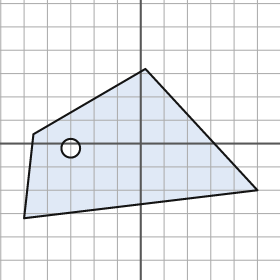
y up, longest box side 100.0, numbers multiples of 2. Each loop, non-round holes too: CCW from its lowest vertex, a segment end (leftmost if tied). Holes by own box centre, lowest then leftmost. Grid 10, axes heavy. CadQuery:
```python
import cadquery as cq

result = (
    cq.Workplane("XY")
    .moveTo(-50.0, -32.0)
    .lineTo(50.0, -20.0)
    .lineTo(2.0, 32.0)
    .lineTo(-46.0, 4.0)
    .close()
    .moveTo(-30.0, -2.0)
    .circle(4.0)
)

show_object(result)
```